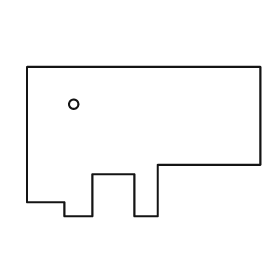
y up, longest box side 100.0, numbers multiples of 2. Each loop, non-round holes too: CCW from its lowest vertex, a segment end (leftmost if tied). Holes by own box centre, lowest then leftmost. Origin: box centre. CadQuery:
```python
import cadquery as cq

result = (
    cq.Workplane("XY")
    .moveTo(-34.0, -32.0)
    .lineTo(-22.0, -32.0)
    .lineTo(-22.0, -14.0)
    .lineTo(-4.0, -14.0)
    .lineTo(-4.0, -32.0)
    .lineTo(6.0, -32.0)
    .lineTo(6.0, -10.0)
    .lineTo(50.0, -10.0)
    .lineTo(50.0, 32.0)
    .lineTo(-50.0, 32.0)
    .lineTo(-50.0, -26.0)
    .lineTo(-34.0, -26.0)
    .close()
    .moveTo(-30.0, 16.0)
    .circle(2.0)
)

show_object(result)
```